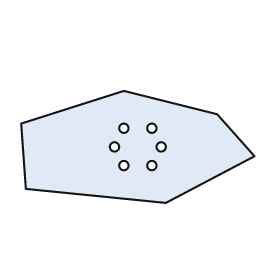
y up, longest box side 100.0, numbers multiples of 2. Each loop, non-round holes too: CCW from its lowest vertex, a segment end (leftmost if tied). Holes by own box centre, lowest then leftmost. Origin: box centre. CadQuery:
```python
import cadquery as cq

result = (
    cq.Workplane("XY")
    .moveTo(12.0, -24.0)
    .lineTo(50.0, -4.0)
    .lineTo(34.0, 14.0)
    .lineTo(-6.0, 24.0)
    .lineTo(-50.0, 10.0)
    .lineTo(-48.0, -18.0)
    .close()
    .moveTo(-6.0, -8.0)
    .circle(2.0)
    .moveTo(6.0, -8.0)
    .circle(2.0)
    .moveTo(-10.0, 0.0)
    .circle(2.0)
    .moveTo(10.0, 0.0)
    .circle(2.0)
    .moveTo(-6.0, 8.0)
    .circle(2.0)
    .moveTo(6.0, 8.0)
    .circle(2.0)
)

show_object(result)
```